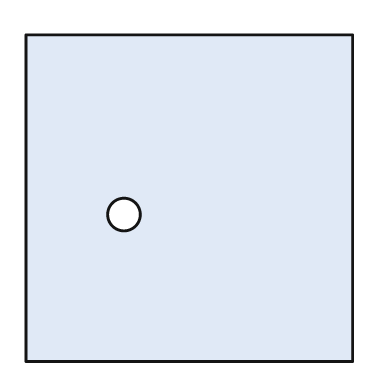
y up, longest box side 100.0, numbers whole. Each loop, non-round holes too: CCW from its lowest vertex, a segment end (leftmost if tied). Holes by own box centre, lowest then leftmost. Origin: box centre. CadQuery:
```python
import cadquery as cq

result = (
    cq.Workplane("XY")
    .moveTo(-50.0, -50.0)
    .lineTo(50.0, -50.0)
    .lineTo(50.0, 50.0)
    .lineTo(-50.0, 50.0)
    .close()
    .moveTo(-20.0, -5.0)
    .circle(5.0)
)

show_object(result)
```